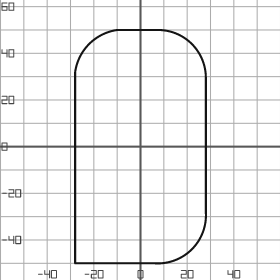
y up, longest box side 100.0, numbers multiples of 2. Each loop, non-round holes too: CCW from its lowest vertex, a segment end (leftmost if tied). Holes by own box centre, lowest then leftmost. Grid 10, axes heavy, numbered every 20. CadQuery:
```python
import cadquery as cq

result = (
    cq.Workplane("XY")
    .moveTo(-28.0, -50.0)
    .lineTo(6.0, -50.0)
    .threePointArc((22.0, -44.0), (28.0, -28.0))
    .lineTo(28.0, 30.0)
    .threePointArc((22.0, 44.0), (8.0, 50.0))
    .lineTo(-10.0, 50.0)
    .threePointArc((-22.0, 44.0), (-28.0, 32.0))
    .close()
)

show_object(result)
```